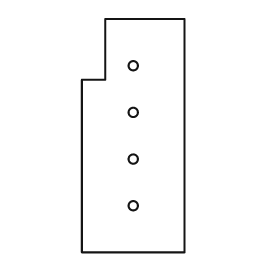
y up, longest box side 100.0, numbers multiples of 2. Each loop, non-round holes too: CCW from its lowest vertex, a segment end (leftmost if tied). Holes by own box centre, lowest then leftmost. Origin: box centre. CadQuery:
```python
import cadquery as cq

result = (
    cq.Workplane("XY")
    .moveTo(-22.0, -50.0)
    .lineTo(22.0, -50.0)
    .lineTo(22.0, 50.0)
    .lineTo(-12.0, 50.0)
    .lineTo(-12.0, 24.0)
    .lineTo(-22.0, 24.0)
    .close()
    .moveTo(0.0, -30.0)
    .circle(2.0)
    .moveTo(0.0, -10.0)
    .circle(2.0)
    .moveTo(0.0, 10.0)
    .circle(2.0)
    .moveTo(0.0, 30.0)
    .circle(2.0)
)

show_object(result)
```